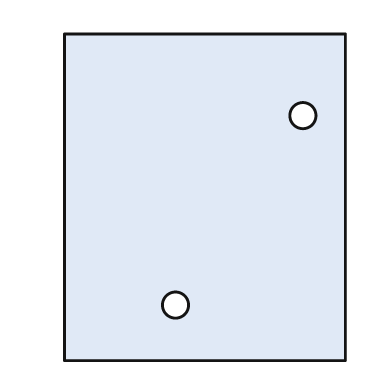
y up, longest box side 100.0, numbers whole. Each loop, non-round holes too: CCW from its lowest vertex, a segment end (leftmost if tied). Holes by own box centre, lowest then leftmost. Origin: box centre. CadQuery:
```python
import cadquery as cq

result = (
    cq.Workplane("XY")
    .moveTo(-43.0, -50.0)
    .lineTo(43.0, -50.0)
    .lineTo(43.0, 50.0)
    .lineTo(-43.0, 50.0)
    .close()
    .moveTo(-9.0, -33.0)
    .circle(4.0)
    .moveTo(30.0, 25.0)
    .circle(4.0)
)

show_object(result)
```